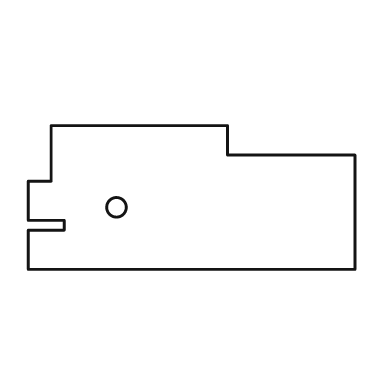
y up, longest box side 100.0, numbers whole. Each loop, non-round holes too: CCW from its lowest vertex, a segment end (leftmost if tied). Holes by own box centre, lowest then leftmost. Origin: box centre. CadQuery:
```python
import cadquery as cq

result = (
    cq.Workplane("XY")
    .moveTo(-50.0, -22.0)
    .lineTo(50.0, -22.0)
    .lineTo(50.0, 13.0)
    .lineTo(11.0, 13.0)
    .lineTo(11.0, 22.0)
    .lineTo(-43.0, 22.0)
    .lineTo(-43.0, 5.0)
    .lineTo(-50.0, 5.0)
    .lineTo(-50.0, -7.0)
    .lineTo(-39.0, -7.0)
    .lineTo(-39.0, -10.0)
    .lineTo(-50.0, -10.0)
    .close()
    .moveTo(-23.0, -3.0)
    .circle(3.0)
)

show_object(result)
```